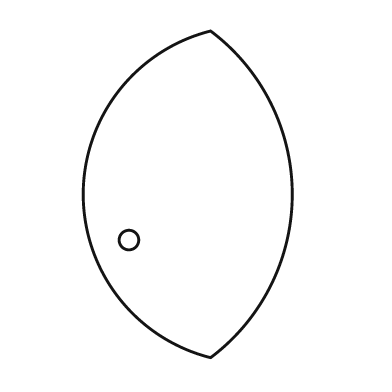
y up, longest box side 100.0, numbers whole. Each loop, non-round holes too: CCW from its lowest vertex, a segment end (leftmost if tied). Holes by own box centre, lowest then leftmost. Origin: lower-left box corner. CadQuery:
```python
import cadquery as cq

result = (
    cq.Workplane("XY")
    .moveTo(39.0, 0.0)
    .threePointArc((64.0, 50.0), (39.0, 100.0))
    .threePointArc((0.0, 50.0), (39.0, 0.0))
    .close()
    .moveTo(14.0, 36.0)
    .circle(3.0)
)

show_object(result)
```